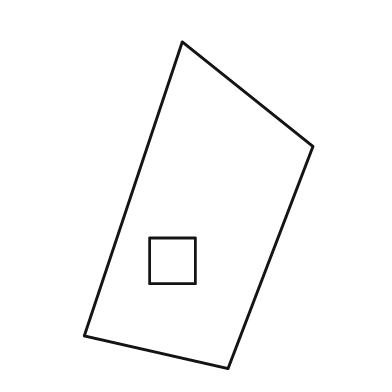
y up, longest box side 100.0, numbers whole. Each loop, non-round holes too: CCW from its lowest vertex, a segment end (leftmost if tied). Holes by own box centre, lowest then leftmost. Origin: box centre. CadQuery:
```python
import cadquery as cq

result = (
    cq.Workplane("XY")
    .moveTo(9.0, -50.0)
    .lineTo(35.0, 18.0)
    .lineTo(-5.0, 50.0)
    .lineTo(-35.0, -40.0)
    .close()
    .moveTo(-15.0, -24.0)
    .lineTo(-1.0, -24.0)
    .lineTo(-1.0, -10.0)
    .lineTo(-15.0, -10.0)
    .close()
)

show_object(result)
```